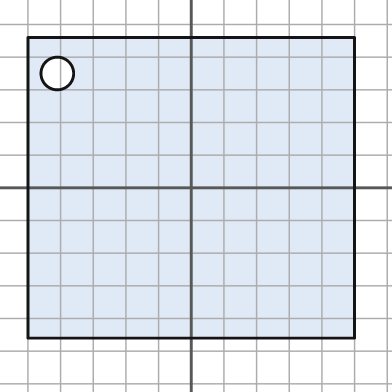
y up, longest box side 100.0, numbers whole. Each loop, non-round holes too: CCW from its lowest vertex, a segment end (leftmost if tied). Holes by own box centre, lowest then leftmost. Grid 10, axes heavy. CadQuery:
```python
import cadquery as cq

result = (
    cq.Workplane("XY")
    .moveTo(-50.0, -46.0)
    .lineTo(50.0, -46.0)
    .lineTo(50.0, 46.0)
    .lineTo(-50.0, 46.0)
    .close()
    .moveTo(-41.0, 35.0)
    .circle(5.0)
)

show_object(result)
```